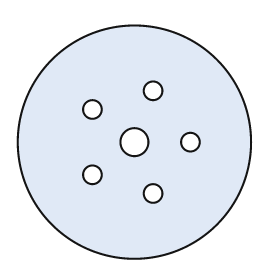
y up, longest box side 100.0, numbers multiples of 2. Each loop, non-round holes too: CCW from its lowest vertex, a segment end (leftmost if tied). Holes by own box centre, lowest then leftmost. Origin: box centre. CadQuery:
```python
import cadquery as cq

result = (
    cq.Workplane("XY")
    .moveTo(0.0, 0.0)
    .circle(50.0)
    .moveTo(8.0, -22.0)
    .circle(4.0)
    .moveTo(-18.0, -14.0)
    .circle(4.0)
    .moveTo(0.0, 0.0)
    .circle(6.0)
    .moveTo(24.0, 0.0)
    .circle(4.0)
    .moveTo(-18.0, 14.0)
    .circle(4.0)
    .moveTo(8.0, 22.0)
    .circle(4.0)
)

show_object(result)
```